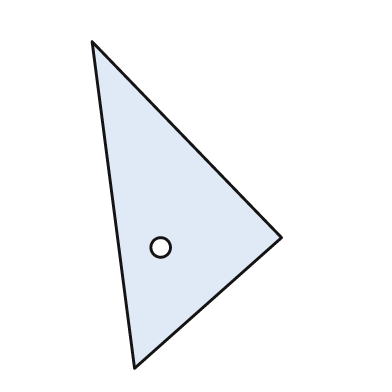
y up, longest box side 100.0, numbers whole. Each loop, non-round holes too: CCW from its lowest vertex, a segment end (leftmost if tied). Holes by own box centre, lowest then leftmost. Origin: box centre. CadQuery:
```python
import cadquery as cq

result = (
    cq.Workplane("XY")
    .moveTo(-16.0, -50.0)
    .lineTo(29.0, -10.0)
    .lineTo(-29.0, 50.0)
    .close()
    .moveTo(-8.0, -13.0)
    .circle(3.0)
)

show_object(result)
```